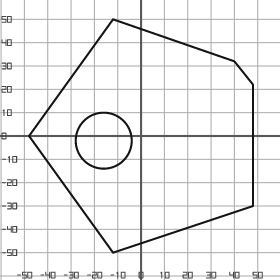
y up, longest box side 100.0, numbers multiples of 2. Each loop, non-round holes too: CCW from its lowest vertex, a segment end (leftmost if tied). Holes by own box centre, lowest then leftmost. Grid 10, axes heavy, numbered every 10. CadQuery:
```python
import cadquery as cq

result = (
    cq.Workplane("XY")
    .moveTo(-12.0, -50.0)
    .lineTo(48.0, -30.0)
    .lineTo(48.0, 22.0)
    .lineTo(40.0, 32.0)
    .lineTo(-12.0, 50.0)
    .lineTo(-48.0, 0.0)
    .close()
    .moveTo(-16.0, -2.0)
    .circle(12.0)
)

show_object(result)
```